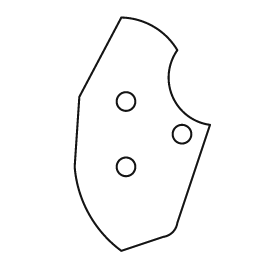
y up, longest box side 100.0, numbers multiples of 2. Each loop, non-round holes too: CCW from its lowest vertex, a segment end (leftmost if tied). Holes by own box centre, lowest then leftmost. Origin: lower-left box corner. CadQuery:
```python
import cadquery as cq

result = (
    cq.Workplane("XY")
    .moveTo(20.0, 0.0)
    .lineTo(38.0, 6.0)
    .threePointArc((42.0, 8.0), (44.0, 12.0))
    .lineTo(58.0, 54.0)
    .threePointArc((42.0, 66.0), (44.0, 86.0))
    .threePointArc((34.0, 96.0), (20.0, 100.0))
    .lineTo(2.0, 66.0)
    .lineTo(0.0, 36.0)
    .threePointArc((6.0, 16.0), (20.0, 0.0))
    .close()
    .moveTo(22.0, 36.0)
    .circle(4.0)
    .moveTo(46.0, 50.0)
    .circle(4.0)
    .moveTo(22.0, 64.0)
    .circle(4.0)
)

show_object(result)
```